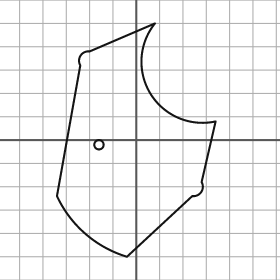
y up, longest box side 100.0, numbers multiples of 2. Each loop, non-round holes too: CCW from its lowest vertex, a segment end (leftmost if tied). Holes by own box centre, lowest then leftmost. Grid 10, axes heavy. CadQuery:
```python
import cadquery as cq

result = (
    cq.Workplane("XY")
    .moveTo(-4.0, -50.0)
    .lineTo(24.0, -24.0)
    .threePointArc((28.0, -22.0), (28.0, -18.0))
    .lineTo(34.0, 8.0)
    .threePointArc((6.0, 20.0), (8.0, 50.0))
    .lineTo(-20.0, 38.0)
    .threePointArc((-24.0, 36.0), (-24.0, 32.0))
    .lineTo(-34.0, -24.0)
    .threePointArc((-22.0, -40.0), (-4.0, -50.0))
    .close()
    .moveTo(-16.0, -2.0)
    .circle(2.0)
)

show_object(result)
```